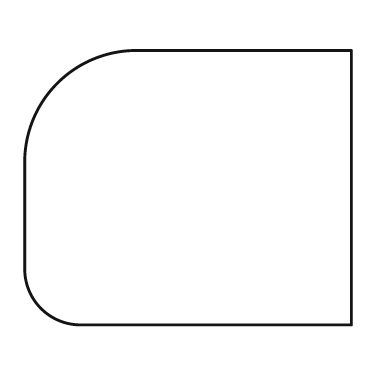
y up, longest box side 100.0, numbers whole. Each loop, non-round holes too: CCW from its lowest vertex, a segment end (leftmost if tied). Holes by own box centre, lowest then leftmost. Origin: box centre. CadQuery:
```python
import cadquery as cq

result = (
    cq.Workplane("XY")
    .moveTo(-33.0, -42.0)
    .lineTo(50.0, -42.0)
    .lineTo(50.0, 42.0)
    .lineTo(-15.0, 42.0)
    .threePointArc((-40.0, 32.0), (-50.0, 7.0))
    .lineTo(-50.0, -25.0)
    .threePointArc((-45.0, -37.0), (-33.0, -42.0))
    .close()
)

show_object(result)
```